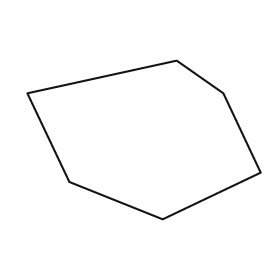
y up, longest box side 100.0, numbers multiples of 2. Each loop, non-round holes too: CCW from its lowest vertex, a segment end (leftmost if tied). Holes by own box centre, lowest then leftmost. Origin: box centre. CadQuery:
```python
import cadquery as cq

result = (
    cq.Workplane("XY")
    .moveTo(8.0, -34.0)
    .lineTo(50.0, -14.0)
    .lineTo(34.0, 20.0)
    .lineTo(14.0, 34.0)
    .lineTo(-50.0, 20.0)
    .lineTo(-32.0, -18.0)
    .close()
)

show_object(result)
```